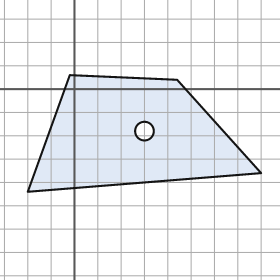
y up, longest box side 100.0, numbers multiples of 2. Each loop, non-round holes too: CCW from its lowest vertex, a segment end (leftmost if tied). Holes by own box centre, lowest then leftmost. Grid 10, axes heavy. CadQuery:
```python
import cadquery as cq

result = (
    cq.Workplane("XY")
    .moveTo(-20.0, -44.0)
    .lineTo(80.0, -36.0)
    .lineTo(44.0, 4.0)
    .lineTo(-2.0, 6.0)
    .close()
    .moveTo(30.0, -18.0)
    .circle(4.0)
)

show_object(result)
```